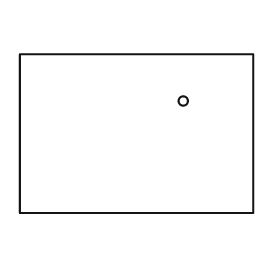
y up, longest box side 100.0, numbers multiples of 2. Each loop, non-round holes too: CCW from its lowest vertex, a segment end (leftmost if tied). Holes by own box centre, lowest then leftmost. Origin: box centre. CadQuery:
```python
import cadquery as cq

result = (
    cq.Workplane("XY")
    .moveTo(-50.0, -34.0)
    .lineTo(50.0, -34.0)
    .lineTo(50.0, 34.0)
    .lineTo(-50.0, 34.0)
    .close()
    .moveTo(20.0, 14.0)
    .circle(2.0)
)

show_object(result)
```